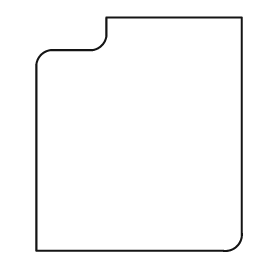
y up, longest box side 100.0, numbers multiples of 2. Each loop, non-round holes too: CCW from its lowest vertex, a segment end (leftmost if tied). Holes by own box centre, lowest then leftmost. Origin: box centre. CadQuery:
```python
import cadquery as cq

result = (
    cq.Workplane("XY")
    .moveTo(-44.0, -50.0)
    .lineTo(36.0, -50.0)
    .threePointArc((42.0, -48.0), (44.0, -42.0))
    .lineTo(44.0, 50.0)
    .lineTo(-14.0, 50.0)
    .lineTo(-14.0, 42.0)
    .threePointArc((-16.0, 38.0), (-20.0, 36.0))
    .lineTo(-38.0, 36.0)
    .threePointArc((-42.0, 34.0), (-44.0, 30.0))
    .close()
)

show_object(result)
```